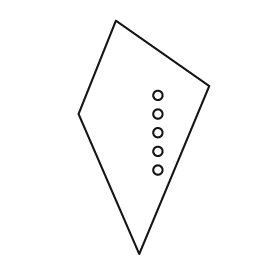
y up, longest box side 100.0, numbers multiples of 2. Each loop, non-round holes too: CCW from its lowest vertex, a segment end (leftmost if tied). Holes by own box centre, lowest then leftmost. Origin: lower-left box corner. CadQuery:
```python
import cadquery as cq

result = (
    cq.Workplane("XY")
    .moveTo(26.0, 0.0)
    .lineTo(56.0, 72.0)
    .lineTo(16.0, 100.0)
    .lineTo(0.0, 60.0)
    .close()
    .moveTo(34.0, 36.0)
    .circle(2.0)
    .moveTo(34.0, 44.0)
    .circle(2.0)
    .moveTo(34.0, 52.0)
    .circle(2.0)
    .moveTo(34.0, 60.0)
    .circle(2.0)
    .moveTo(34.0, 68.0)
    .circle(2.0)
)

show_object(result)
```